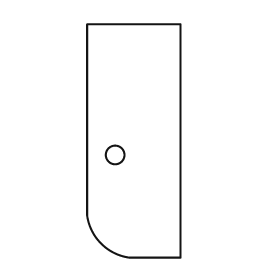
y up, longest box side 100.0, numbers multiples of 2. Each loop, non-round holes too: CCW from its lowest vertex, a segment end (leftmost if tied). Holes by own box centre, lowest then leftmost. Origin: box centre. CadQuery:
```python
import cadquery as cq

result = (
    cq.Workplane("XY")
    .moveTo(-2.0, -50.0)
    .lineTo(20.0, -50.0)
    .lineTo(20.0, 50.0)
    .lineTo(-20.0, 50.0)
    .lineTo(-20.0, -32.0)
    .threePointArc((-14.0, -44.0), (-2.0, -50.0))
    .close()
    .moveTo(-8.0, -6.0)
    .circle(4.0)
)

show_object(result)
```